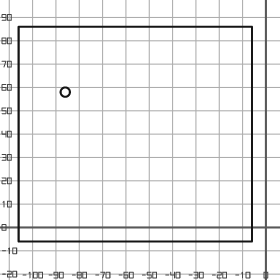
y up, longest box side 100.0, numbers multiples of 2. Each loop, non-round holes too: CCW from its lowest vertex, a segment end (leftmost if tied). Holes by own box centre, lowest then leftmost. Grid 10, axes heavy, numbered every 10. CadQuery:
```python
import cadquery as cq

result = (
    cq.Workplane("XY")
    .moveTo(-106.0, -6.0)
    .lineTo(-6.0, -6.0)
    .lineTo(-6.0, 86.0)
    .lineTo(-106.0, 86.0)
    .close()
    .moveTo(-86.0, 58.0)
    .circle(2.0)
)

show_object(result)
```